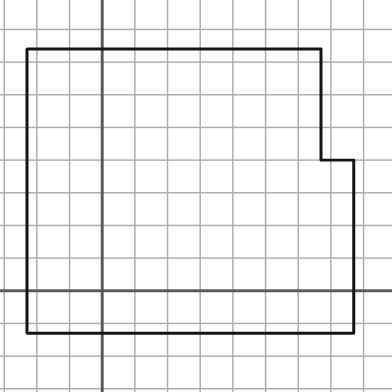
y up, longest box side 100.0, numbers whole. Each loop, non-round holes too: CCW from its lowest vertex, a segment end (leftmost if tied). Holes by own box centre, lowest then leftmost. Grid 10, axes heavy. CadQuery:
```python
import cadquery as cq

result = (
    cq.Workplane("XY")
    .moveTo(-23.0, -13.0)
    .lineTo(77.0, -13.0)
    .lineTo(77.0, 40.0)
    .lineTo(67.0, 40.0)
    .lineTo(67.0, 74.0)
    .lineTo(-23.0, 74.0)
    .close()
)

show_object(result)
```